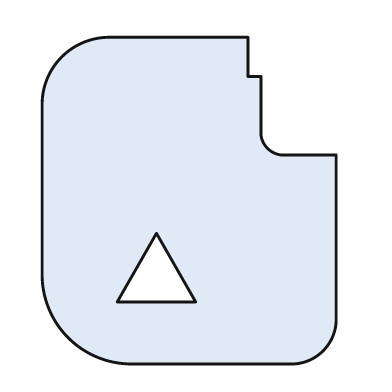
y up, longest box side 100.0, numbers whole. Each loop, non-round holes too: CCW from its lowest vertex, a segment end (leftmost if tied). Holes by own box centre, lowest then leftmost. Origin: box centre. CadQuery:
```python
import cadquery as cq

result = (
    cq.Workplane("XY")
    .moveTo(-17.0, -50.0)
    .lineTo(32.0, -50.0)
    .threePointArc((41.0, -46.0), (45.0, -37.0))
    .lineTo(45.0, 14.0)
    .lineTo(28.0, 14.0)
    .threePointArc((24.0, 16.0), (22.0, 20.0))
    .lineTo(22.0, 38.0)
    .lineTo(18.0, 38.0)
    .lineTo(18.0, 50.0)
    .lineTo(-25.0, 50.0)
    .threePointArc((-39.0, 44.0), (-45.0, 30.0))
    .lineTo(-45.0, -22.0)
    .threePointArc((-37.0, -42.0), (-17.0, -50.0))
    .close()
    .moveTo(-22.0, -31.0)
    .lineTo(2.0, -31.0)
    .lineTo(-10.0, -10.0)
    .close()
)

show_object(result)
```